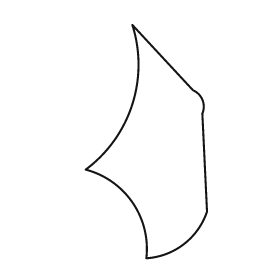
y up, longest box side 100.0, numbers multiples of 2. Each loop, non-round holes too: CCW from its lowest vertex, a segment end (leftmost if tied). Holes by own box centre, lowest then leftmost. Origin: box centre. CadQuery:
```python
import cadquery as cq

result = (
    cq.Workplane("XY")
    .moveTo(0.0, -50.0)
    .threePointArc((16.0, -44.0), (26.0, -30.0))
    .lineTo(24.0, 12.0)
    .threePointArc((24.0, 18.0), (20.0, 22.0))
    .lineTo(-6.0, 50.0)
    .threePointArc((-6.0, 16.0), (-26.0, -12.0))
    .threePointArc((-6.0, -26.0), (0.0, -50.0))
    .close()
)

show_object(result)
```